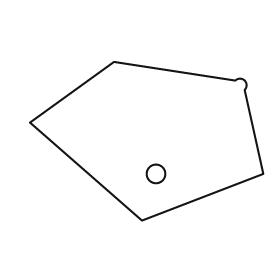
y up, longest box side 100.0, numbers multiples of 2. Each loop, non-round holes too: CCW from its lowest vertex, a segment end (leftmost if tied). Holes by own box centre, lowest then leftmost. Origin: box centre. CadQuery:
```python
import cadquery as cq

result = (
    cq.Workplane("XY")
    .moveTo(-2.0, -34.0)
    .lineTo(50.0, -14.0)
    .lineTo(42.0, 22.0)
    .threePointArc((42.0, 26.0), (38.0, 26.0))
    .lineTo(-14.0, 34.0)
    .lineTo(-50.0, 8.0)
    .close()
    .moveTo(4.0, -14.0)
    .circle(4.0)
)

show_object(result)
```